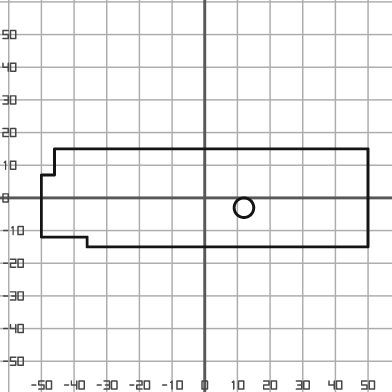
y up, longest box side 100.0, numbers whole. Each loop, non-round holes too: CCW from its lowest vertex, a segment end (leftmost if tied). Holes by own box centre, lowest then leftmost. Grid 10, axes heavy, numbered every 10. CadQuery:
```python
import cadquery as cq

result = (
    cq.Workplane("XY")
    .moveTo(-36.0, -15.0)
    .lineTo(50.0, -15.0)
    .lineTo(50.0, 15.0)
    .lineTo(-46.0, 15.0)
    .lineTo(-46.0, 7.0)
    .lineTo(-50.0, 7.0)
    .lineTo(-50.0, -12.0)
    .lineTo(-36.0, -12.0)
    .close()
    .moveTo(12.0, -3.0)
    .circle(3.0)
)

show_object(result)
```